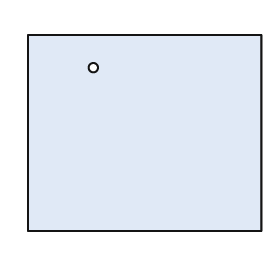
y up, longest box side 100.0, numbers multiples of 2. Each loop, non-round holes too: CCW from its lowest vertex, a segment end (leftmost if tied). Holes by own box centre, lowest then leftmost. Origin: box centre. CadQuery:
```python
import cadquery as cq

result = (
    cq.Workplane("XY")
    .moveTo(-50.0, -42.0)
    .lineTo(50.0, -42.0)
    .lineTo(50.0, 42.0)
    .lineTo(-50.0, 42.0)
    .close()
    .moveTo(-22.0, 28.0)
    .circle(2.0)
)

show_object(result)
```